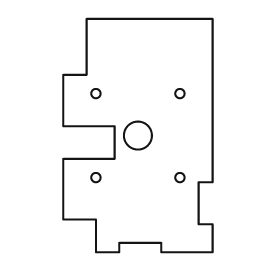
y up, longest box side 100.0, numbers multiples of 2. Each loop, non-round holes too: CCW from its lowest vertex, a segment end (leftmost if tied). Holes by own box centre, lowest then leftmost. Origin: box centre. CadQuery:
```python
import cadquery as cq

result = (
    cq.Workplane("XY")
    .moveTo(-18.0, -50.0)
    .lineTo(-8.0, -50.0)
    .lineTo(-8.0, -46.0)
    .lineTo(10.0, -46.0)
    .lineTo(10.0, -50.0)
    .lineTo(32.0, -50.0)
    .lineTo(32.0, -38.0)
    .lineTo(26.0, -38.0)
    .lineTo(26.0, -20.0)
    .lineTo(32.0, -20.0)
    .lineTo(32.0, 50.0)
    .lineTo(-22.0, 50.0)
    .lineTo(-22.0, 26.0)
    .lineTo(-32.0, 26.0)
    .lineTo(-32.0, 4.0)
    .lineTo(-10.0, 4.0)
    .lineTo(-10.0, -10.0)
    .lineTo(-32.0, -10.0)
    .lineTo(-32.0, -36.0)
    .lineTo(-18.0, -36.0)
    .close()
    .moveTo(-18.0, -18.0)
    .circle(2.0)
    .moveTo(18.0, -18.0)
    .circle(2.0)
    .moveTo(0.0, 0.0)
    .circle(6.0)
    .moveTo(-18.0, 18.0)
    .circle(2.0)
    .moveTo(18.0, 18.0)
    .circle(2.0)
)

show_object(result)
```